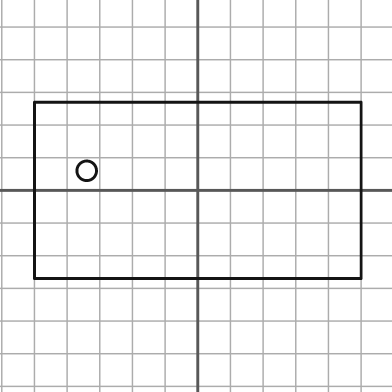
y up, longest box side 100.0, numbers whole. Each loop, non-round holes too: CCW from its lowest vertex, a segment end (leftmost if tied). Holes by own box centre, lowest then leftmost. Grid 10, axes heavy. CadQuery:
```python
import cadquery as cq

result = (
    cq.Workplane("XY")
    .moveTo(-50.0, -27.0)
    .lineTo(50.0, -27.0)
    .lineTo(50.0, 27.0)
    .lineTo(-50.0, 27.0)
    .close()
    .moveTo(-34.0, 6.0)
    .circle(3.0)
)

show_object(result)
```